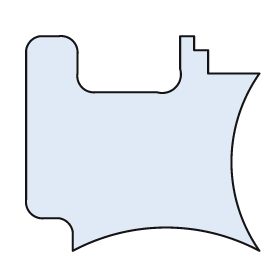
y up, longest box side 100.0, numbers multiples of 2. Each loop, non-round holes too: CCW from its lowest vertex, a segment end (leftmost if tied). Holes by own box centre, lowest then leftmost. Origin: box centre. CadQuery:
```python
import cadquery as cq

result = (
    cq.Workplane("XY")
    .moveTo(-30.0, -46.0)
    .threePointArc((10.0, -36.0), (50.0, -46.0))
    .threePointArc((38.0, -8.0), (50.0, 30.0))
    .lineTo(28.0, 30.0)
    .lineTo(28.0, 40.0)
    .lineTo(22.0, 40.0)
    .lineTo(22.0, 46.0)
    .lineTo(16.0, 46.0)
    .lineTo(16.0, 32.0)
    .threePointArc((14.0, 24.0), (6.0, 22.0))
    .lineTo(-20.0, 22.0)
    .threePointArc((-26.0, 24.0), (-28.0, 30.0))
    .lineTo(-28.0, 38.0)
    .threePointArc((-30.0, 44.0), (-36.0, 46.0))
    .lineTo(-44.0, 46.0)
    .threePointArc((-48.0, 44.0), (-50.0, 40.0))
    .lineTo(-50.0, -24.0)
    .threePointArc((-48.0, -30.0), (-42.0, -32.0))
    .lineTo(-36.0, -32.0)
    .threePointArc((-32.0, -34.0), (-30.0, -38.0))
    .close()
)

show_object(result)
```